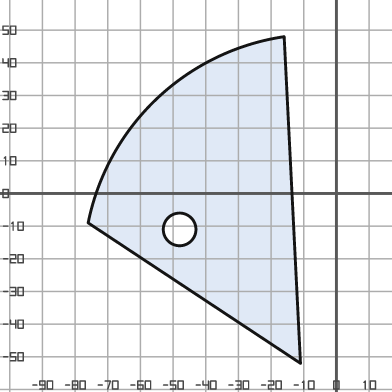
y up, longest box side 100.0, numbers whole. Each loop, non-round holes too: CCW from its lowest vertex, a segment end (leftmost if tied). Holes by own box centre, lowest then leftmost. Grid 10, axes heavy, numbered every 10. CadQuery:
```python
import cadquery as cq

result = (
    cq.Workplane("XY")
    .moveTo(-11.0, -52.0)
    .lineTo(-16.0, 48.0)
    .threePointArc((-55.0, 29.0), (-76.0, -9.0))
    .close()
    .moveTo(-48.0, -11.0)
    .circle(5.0)
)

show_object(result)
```